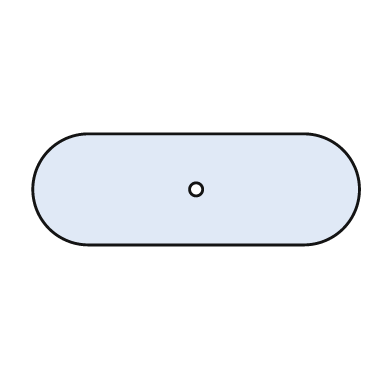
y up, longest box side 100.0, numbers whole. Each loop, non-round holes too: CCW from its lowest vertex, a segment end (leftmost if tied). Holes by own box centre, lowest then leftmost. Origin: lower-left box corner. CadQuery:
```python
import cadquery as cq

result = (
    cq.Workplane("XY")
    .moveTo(17.0, 0.0)
    .lineTo(83.0, 0.0)
    .threePointArc((100.0, 17.0), (83.0, 34.0))
    .lineTo(17.0, 34.0)
    .threePointArc((0.0, 17.0), (17.0, 0.0))
    .close()
    .moveTo(50.0, 17.0)
    .circle(2.0)
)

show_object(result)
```